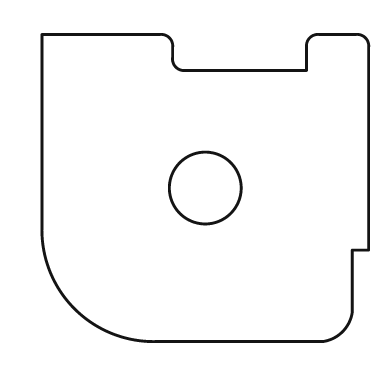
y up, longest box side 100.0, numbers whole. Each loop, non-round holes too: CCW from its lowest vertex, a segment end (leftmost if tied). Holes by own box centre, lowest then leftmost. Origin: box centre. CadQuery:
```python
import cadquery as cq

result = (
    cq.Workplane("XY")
    .moveTo(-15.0, -47.0)
    .lineTo(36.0, -47.0)
    .threePointArc((42.0, -44.0), (45.0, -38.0))
    .lineTo(45.0, -19.0)
    .lineTo(50.0, -19.0)
    .lineTo(50.0, 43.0)
    .threePointArc((49.0, 46.0), (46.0, 47.0))
    .lineTo(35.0, 47.0)
    .threePointArc((32.0, 46.0), (31.0, 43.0))
    .lineTo(31.0, 36.0)
    .lineTo(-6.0, 36.0)
    .threePointArc((-9.0, 37.0), (-10.0, 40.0))
    .lineTo(-10.0, 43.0)
    .threePointArc((-11.0, 46.0), (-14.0, 47.0))
    .lineTo(-50.0, 47.0)
    .lineTo(-50.0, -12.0)
    .threePointArc((-40.0, -37.0), (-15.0, -47.0))
    .close()
    .moveTo(0.0, 0.0)
    .circle(11.0)
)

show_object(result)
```